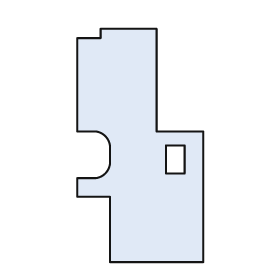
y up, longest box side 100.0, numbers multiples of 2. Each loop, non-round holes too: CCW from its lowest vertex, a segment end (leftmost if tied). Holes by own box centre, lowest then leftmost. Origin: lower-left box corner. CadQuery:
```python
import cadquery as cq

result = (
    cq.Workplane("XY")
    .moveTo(14.0, 0.0)
    .lineTo(54.0, 0.0)
    .lineTo(54.0, 56.0)
    .lineTo(34.0, 56.0)
    .lineTo(34.0, 100.0)
    .lineTo(10.0, 100.0)
    .lineTo(10.0, 96.0)
    .lineTo(0.0, 96.0)
    .lineTo(0.0, 56.0)
    .lineTo(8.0, 56.0)
    .threePointArc((12.0, 54.0), (14.0, 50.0))
    .lineTo(14.0, 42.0)
    .threePointArc((12.0, 38.0), (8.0, 36.0))
    .lineTo(0.0, 36.0)
    .lineTo(0.0, 28.0)
    .lineTo(14.0, 28.0)
    .close()
    .moveTo(38.0, 38.0)
    .lineTo(46.0, 38.0)
    .lineTo(46.0, 50.0)
    .lineTo(38.0, 50.0)
    .close()
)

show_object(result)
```